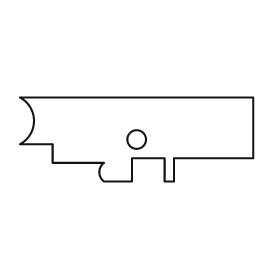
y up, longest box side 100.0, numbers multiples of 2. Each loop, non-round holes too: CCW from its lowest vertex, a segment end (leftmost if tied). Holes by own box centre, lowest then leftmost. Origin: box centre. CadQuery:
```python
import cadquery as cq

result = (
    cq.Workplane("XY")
    .moveTo(-14.0, -18.0)
    .lineTo(-2.0, -18.0)
    .lineTo(-2.0, -8.0)
    .lineTo(12.0, -8.0)
    .lineTo(12.0, -18.0)
    .lineTo(16.0, -18.0)
    .lineTo(16.0, -8.0)
    .lineTo(50.0, -8.0)
    .lineTo(50.0, 18.0)
    .lineTo(-50.0, 18.0)
    .threePointArc((-44.0, 8.0), (-50.0, -2.0))
    .lineTo(-36.0, -2.0)
    .lineTo(-36.0, -10.0)
    .lineTo(-14.0, -10.0)
    .threePointArc((-16.0, -14.0), (-14.0, -18.0))
    .close()
    .moveTo(0.0, 0.0)
    .circle(4.0)
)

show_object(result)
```